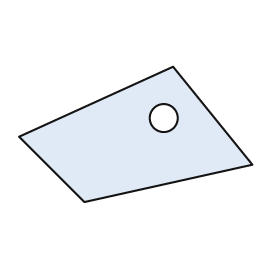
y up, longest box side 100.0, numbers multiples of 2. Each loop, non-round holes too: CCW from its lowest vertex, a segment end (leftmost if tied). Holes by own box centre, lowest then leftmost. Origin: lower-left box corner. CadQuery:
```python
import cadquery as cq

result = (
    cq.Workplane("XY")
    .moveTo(28.0, 0.0)
    .lineTo(100.0, 16.0)
    .lineTo(66.0, 58.0)
    .lineTo(0.0, 28.0)
    .close()
    .moveTo(62.0, 36.0)
    .circle(6.0)
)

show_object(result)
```